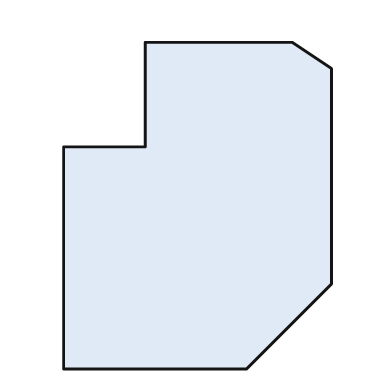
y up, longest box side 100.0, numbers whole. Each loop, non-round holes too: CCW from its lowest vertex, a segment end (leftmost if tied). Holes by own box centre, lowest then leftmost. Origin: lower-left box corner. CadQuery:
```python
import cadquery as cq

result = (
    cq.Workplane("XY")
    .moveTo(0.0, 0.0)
    .lineTo(56.0, 0.0)
    .lineTo(82.0, 26.0)
    .lineTo(82.0, 92.0)
    .lineTo(70.0, 100.0)
    .lineTo(25.0, 100.0)
    .lineTo(25.0, 68.0)
    .lineTo(0.0, 68.0)
    .close()
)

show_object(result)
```